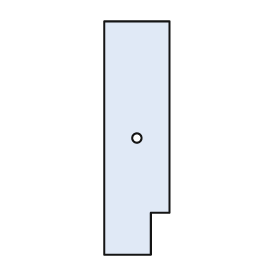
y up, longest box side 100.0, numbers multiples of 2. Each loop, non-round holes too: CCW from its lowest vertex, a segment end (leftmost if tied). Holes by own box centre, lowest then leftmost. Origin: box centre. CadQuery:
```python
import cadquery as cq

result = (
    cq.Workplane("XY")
    .moveTo(-14.0, -50.0)
    .lineTo(6.0, -50.0)
    .lineTo(6.0, -32.0)
    .lineTo(14.0, -32.0)
    .lineTo(14.0, 50.0)
    .lineTo(-14.0, 50.0)
    .close()
    .moveTo(0.0, 0.0)
    .circle(2.0)
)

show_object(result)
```